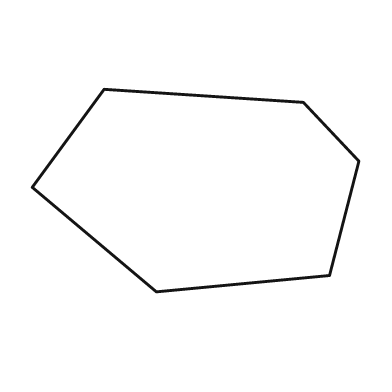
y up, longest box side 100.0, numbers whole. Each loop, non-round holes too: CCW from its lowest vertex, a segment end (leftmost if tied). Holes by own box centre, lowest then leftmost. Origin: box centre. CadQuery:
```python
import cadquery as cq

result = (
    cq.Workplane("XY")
    .moveTo(-12.0, -31.0)
    .lineTo(41.0, -26.0)
    .lineTo(50.0, 9.0)
    .lineTo(33.0, 27.0)
    .lineTo(-28.0, 31.0)
    .lineTo(-50.0, 1.0)
    .close()
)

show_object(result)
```